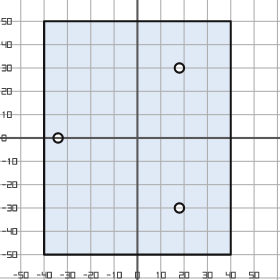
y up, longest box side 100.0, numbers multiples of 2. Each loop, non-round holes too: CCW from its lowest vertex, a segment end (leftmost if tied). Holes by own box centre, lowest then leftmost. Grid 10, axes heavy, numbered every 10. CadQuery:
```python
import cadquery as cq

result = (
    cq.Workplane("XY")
    .moveTo(-40.0, -50.0)
    .lineTo(40.0, -50.0)
    .lineTo(40.0, 50.0)
    .lineTo(-40.0, 50.0)
    .close()
    .moveTo(18.0, -30.0)
    .circle(2.0)
    .moveTo(-34.0, 0.0)
    .circle(2.0)
    .moveTo(18.0, 30.0)
    .circle(2.0)
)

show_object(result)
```